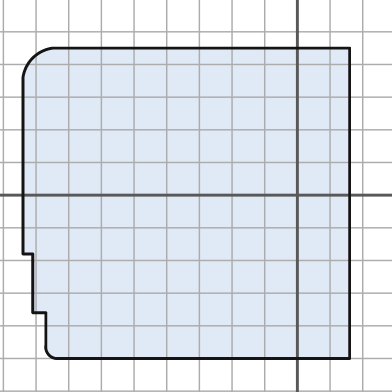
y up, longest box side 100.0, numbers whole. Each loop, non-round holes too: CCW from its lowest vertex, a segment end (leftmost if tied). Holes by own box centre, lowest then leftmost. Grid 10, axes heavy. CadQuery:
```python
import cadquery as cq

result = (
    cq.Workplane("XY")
    .moveTo(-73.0, -50.0)
    .lineTo(16.0, -50.0)
    .lineTo(16.0, 45.0)
    .lineTo(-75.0, 45.0)
    .threePointArc((-81.0, 42.0), (-84.0, 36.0))
    .lineTo(-84.0, -18.0)
    .lineTo(-81.0, -18.0)
    .lineTo(-81.0, -36.0)
    .lineTo(-77.0, -36.0)
    .lineTo(-77.0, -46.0)
    .threePointArc((-76.0, -49.0), (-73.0, -50.0))
    .close()
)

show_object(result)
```